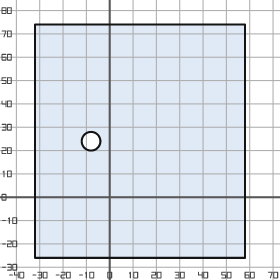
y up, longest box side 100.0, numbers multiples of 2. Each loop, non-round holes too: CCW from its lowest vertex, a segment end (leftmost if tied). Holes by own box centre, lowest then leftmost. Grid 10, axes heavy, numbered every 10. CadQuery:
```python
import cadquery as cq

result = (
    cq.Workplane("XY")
    .moveTo(-32.0, -26.0)
    .lineTo(58.0, -26.0)
    .lineTo(58.0, 74.0)
    .lineTo(-32.0, 74.0)
    .close()
    .moveTo(-8.0, 24.0)
    .circle(4.0)
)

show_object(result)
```